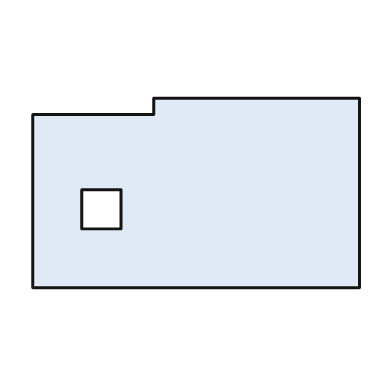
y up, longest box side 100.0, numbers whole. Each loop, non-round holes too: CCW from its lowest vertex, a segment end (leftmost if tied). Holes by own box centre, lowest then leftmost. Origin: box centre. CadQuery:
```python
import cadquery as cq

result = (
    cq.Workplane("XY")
    .moveTo(-50.0, -29.0)
    .lineTo(50.0, -29.0)
    .lineTo(50.0, 29.0)
    .lineTo(-13.0, 29.0)
    .lineTo(-13.0, 24.0)
    .lineTo(-50.0, 24.0)
    .close()
    .moveTo(-35.0, -11.0)
    .lineTo(-23.0, -11.0)
    .lineTo(-23.0, 1.0)
    .lineTo(-35.0, 1.0)
    .close()
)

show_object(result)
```